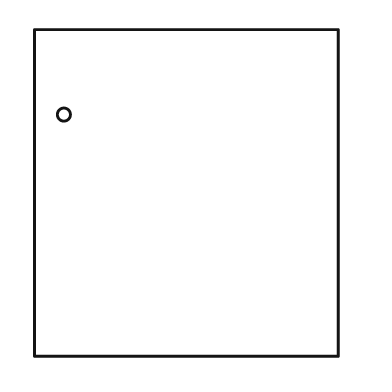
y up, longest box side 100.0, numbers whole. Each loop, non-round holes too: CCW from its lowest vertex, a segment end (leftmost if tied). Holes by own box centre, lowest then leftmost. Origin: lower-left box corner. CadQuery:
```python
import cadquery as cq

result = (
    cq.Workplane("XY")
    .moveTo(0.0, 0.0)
    .lineTo(93.0, 0.0)
    .lineTo(93.0, 100.0)
    .lineTo(0.0, 100.0)
    .close()
    .moveTo(9.0, 74.0)
    .circle(2.0)
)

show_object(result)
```